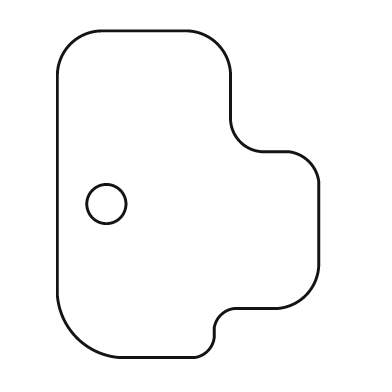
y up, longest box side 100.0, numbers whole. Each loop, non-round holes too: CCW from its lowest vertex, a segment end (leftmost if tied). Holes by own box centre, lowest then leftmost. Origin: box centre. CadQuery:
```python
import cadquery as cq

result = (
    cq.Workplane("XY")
    .moveTo(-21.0, -50.0)
    .lineTo(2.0, -50.0)
    .threePointArc((6.0, -48.0), (8.0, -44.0))
    .lineTo(8.0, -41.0)
    .threePointArc((10.0, -37.0), (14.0, -35.0))
    .lineTo(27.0, -35.0)
    .threePointArc((36.0, -31.0), (40.0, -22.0))
    .lineTo(40.0, 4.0)
    .threePointArc((37.0, 10.0), (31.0, 13.0))
    .lineTo(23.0, 13.0)
    .threePointArc((16.0, 16.0), (13.0, 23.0))
    .lineTo(13.0, 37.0)
    .threePointArc((9.0, 46.0), (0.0, 50.0))
    .lineTo(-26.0, 50.0)
    .threePointArc((-36.0, 46.0), (-40.0, 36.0))
    .lineTo(-40.0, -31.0)
    .threePointArc((-34.0, -44.0), (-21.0, -50.0))
    .close()
    .moveTo(-25.0, -3.0)
    .circle(6.0)
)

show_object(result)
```